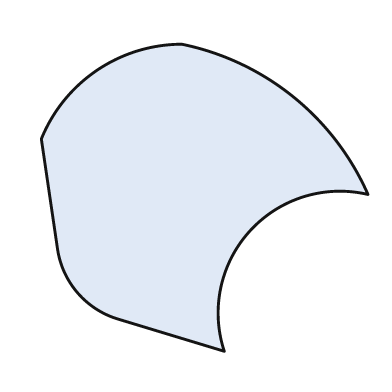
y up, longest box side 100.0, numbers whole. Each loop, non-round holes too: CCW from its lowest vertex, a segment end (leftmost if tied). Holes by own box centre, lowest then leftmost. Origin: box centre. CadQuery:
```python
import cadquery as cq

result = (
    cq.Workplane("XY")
    .moveTo(6.0, -47.0)
    .threePointArc((14.0, -10.0), (50.0, 1.0))
    .threePointArc((27.0, 31.0), (-7.0, 47.0))
    .threePointArc((-33.0, 39.0), (-50.0, 18.0))
    .lineTo(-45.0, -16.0)
    .threePointArc((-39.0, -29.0), (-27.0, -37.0))
    .close()
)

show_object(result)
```